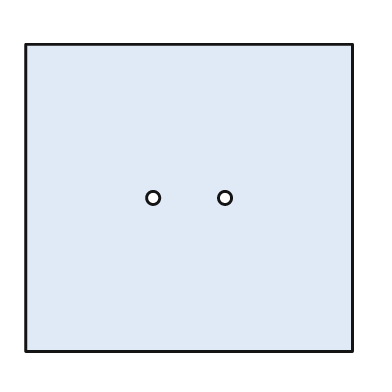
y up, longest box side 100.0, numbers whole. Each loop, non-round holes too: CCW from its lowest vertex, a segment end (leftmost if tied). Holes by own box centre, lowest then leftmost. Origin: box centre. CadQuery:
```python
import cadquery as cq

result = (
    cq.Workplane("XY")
    .moveTo(-50.0, -47.0)
    .lineTo(50.0, -47.0)
    .lineTo(50.0, 47.0)
    .lineTo(-50.0, 47.0)
    .close()
    .moveTo(-11.0, 0.0)
    .circle(2.0)
    .moveTo(11.0, 0.0)
    .circle(2.0)
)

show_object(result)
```